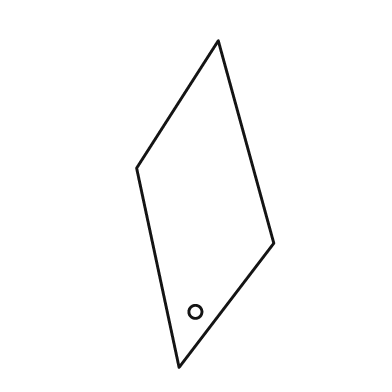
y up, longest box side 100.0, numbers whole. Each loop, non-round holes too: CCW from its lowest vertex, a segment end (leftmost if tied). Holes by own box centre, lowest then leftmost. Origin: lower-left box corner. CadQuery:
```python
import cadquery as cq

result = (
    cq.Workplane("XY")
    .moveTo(13.0, 0.0)
    .lineTo(42.0, 38.0)
    .lineTo(25.0, 100.0)
    .lineTo(0.0, 61.0)
    .close()
    .moveTo(18.0, 17.0)
    .circle(2.0)
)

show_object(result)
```